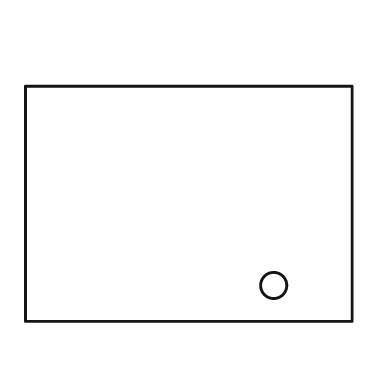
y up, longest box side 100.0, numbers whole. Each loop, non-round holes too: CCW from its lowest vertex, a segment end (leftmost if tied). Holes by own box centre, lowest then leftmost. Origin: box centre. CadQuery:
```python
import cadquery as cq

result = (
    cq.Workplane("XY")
    .moveTo(-50.0, -36.0)
    .lineTo(50.0, -36.0)
    .lineTo(50.0, 36.0)
    .lineTo(-50.0, 36.0)
    .close()
    .moveTo(26.0, -25.0)
    .circle(4.0)
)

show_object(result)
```